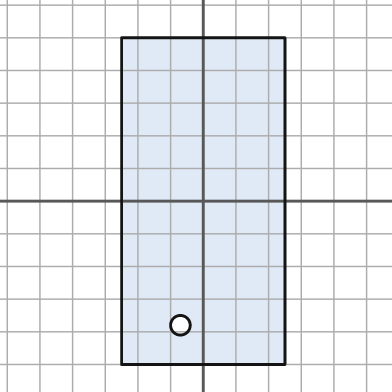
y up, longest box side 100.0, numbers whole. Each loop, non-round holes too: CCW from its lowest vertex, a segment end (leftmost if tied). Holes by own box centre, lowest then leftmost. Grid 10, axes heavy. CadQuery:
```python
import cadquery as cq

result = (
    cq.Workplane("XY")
    .moveTo(-25.0, -50.0)
    .lineTo(25.0, -50.0)
    .lineTo(25.0, 50.0)
    .lineTo(-25.0, 50.0)
    .close()
    .moveTo(-7.0, -38.0)
    .circle(3.0)
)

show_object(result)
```